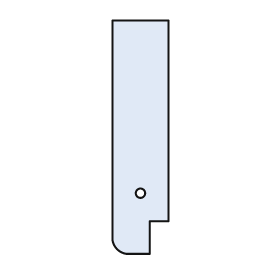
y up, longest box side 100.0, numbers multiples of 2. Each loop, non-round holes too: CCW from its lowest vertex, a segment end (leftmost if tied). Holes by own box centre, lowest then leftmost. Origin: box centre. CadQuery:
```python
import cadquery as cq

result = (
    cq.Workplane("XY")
    .moveTo(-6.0, -50.0)
    .lineTo(4.0, -50.0)
    .lineTo(4.0, -36.0)
    .lineTo(12.0, -36.0)
    .lineTo(12.0, 50.0)
    .lineTo(-12.0, 50.0)
    .lineTo(-12.0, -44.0)
    .threePointArc((-10.0, -48.0), (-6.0, -50.0))
    .close()
    .moveTo(0.0, -24.0)
    .circle(2.0)
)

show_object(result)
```